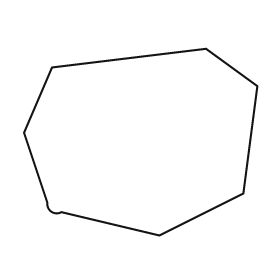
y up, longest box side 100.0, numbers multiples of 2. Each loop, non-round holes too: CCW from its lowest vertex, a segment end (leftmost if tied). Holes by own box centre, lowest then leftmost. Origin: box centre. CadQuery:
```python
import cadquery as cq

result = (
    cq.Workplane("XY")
    .moveTo(8.0, -40.0)
    .lineTo(44.0, -22.0)
    .lineTo(50.0, 24.0)
    .lineTo(28.0, 40.0)
    .lineTo(-38.0, 32.0)
    .lineTo(-50.0, 4.0)
    .lineTo(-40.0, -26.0)
    .threePointArc((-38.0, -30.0), (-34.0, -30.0))
    .close()
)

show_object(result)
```